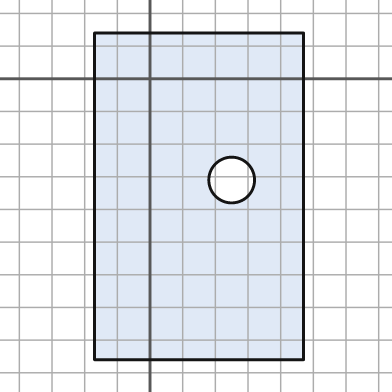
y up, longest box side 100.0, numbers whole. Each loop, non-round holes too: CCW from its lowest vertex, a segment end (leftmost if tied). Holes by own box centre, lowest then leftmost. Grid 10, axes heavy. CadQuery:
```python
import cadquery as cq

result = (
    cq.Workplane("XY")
    .moveTo(-17.0, -86.0)
    .lineTo(47.0, -86.0)
    .lineTo(47.0, 14.0)
    .lineTo(-17.0, 14.0)
    .close()
    .moveTo(25.0, -31.0)
    .circle(7.0)
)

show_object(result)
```